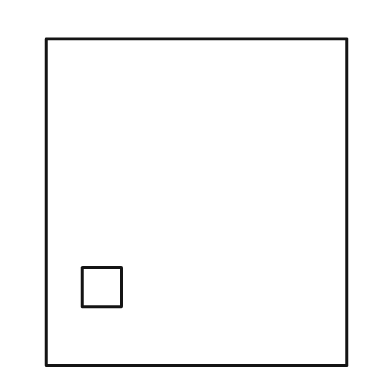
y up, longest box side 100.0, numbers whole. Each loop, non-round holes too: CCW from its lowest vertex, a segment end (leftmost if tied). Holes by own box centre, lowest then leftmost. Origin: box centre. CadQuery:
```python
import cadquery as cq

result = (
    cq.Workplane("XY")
    .moveTo(-46.0, -50.0)
    .lineTo(46.0, -50.0)
    .lineTo(46.0, 50.0)
    .lineTo(-46.0, 50.0)
    .close()
    .moveTo(-35.0, -32.0)
    .lineTo(-23.0, -32.0)
    .lineTo(-23.0, -20.0)
    .lineTo(-35.0, -20.0)
    .close()
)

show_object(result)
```